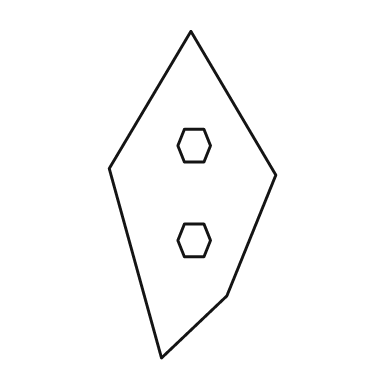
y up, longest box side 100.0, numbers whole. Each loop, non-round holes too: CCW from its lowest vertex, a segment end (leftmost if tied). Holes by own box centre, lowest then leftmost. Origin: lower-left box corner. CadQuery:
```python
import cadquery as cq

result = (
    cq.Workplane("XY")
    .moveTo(16.0, 0.0)
    .lineTo(36.0, 19.0)
    .lineTo(51.0, 56.0)
    .lineTo(25.0, 100.0)
    .lineTo(0.0, 58.0)
    .close()
    .moveTo(23.0, 31.0)
    .lineTo(29.0, 31.0)
    .lineTo(31.0, 36.0)
    .lineTo(29.0, 41.0)
    .lineTo(23.0, 41.0)
    .lineTo(21.0, 36.0)
    .close()
    .moveTo(23.0, 60.0)
    .lineTo(29.0, 60.0)
    .lineTo(31.0, 65.0)
    .lineTo(29.0, 70.0)
    .lineTo(23.0, 70.0)
    .lineTo(21.0, 65.0)
    .close()
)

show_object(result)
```